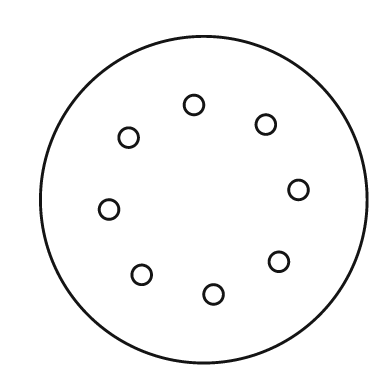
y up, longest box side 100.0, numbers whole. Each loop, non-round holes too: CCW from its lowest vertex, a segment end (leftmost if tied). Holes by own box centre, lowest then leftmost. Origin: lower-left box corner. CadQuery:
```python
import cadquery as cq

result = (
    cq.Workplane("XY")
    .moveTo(50.0, 50.0)
    .circle(50.0)
    .moveTo(53.0, 21.0)
    .circle(3.0)
    .moveTo(31.0, 27.0)
    .circle(3.0)
    .moveTo(73.0, 31.0)
    .circle(3.0)
    .moveTo(21.0, 47.0)
    .circle(3.0)
    .moveTo(79.0, 53.0)
    .circle(3.0)
    .moveTo(27.0, 69.0)
    .circle(3.0)
    .moveTo(69.0, 73.0)
    .circle(3.0)
    .moveTo(47.0, 79.0)
    .circle(3.0)
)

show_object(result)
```